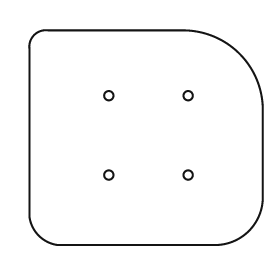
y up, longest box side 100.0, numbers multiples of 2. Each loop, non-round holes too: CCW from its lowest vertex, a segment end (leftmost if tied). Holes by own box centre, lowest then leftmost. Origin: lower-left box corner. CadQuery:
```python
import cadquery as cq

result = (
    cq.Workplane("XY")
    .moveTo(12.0, 0.0)
    .lineTo(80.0, 0.0)
    .threePointArc((94.0, 6.0), (100.0, 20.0))
    .lineTo(100.0, 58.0)
    .threePointArc((90.0, 82.0), (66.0, 92.0))
    .lineTo(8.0, 92.0)
    .threePointArc((2.0, 90.0), (0.0, 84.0))
    .lineTo(0.0, 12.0)
    .threePointArc((4.0, 4.0), (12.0, 0.0))
    .close()
    .moveTo(34.0, 30.0)
    .circle(2.0)
    .moveTo(68.0, 30.0)
    .circle(2.0)
    .moveTo(34.0, 64.0)
    .circle(2.0)
    .moveTo(68.0, 64.0)
    .circle(2.0)
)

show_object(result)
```